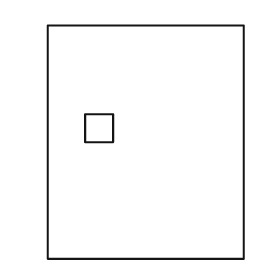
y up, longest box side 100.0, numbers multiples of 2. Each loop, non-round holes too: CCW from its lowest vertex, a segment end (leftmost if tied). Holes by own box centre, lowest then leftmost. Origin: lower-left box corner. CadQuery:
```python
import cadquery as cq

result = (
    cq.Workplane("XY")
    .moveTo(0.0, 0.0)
    .lineTo(84.0, 0.0)
    .lineTo(84.0, 100.0)
    .lineTo(0.0, 100.0)
    .close()
    .moveTo(16.0, 50.0)
    .lineTo(28.0, 50.0)
    .lineTo(28.0, 62.0)
    .lineTo(16.0, 62.0)
    .close()
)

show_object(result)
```